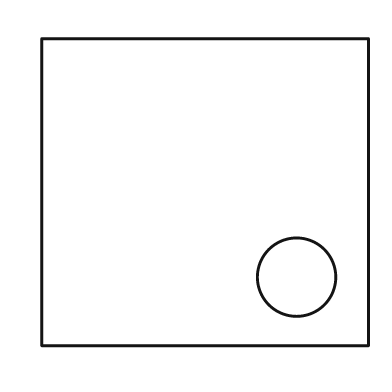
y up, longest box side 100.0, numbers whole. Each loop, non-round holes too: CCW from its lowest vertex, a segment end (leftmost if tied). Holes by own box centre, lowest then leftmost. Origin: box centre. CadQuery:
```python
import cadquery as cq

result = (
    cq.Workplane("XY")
    .moveTo(-50.0, -47.0)
    .lineTo(50.0, -47.0)
    .lineTo(50.0, 47.0)
    .lineTo(-50.0, 47.0)
    .close()
    .moveTo(28.0, -26.0)
    .circle(12.0)
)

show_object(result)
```